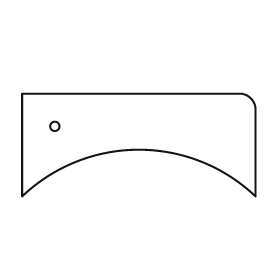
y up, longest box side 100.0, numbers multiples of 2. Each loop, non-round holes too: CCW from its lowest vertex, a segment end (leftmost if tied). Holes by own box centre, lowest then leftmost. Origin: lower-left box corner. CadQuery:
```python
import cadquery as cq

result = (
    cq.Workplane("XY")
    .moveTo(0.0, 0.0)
    .threePointArc((50.0, 20.0), (100.0, 0.0))
    .lineTo(100.0, 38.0)
    .threePointArc((98.0, 42.0), (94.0, 44.0))
    .lineTo(0.0, 44.0)
    .close()
    .moveTo(14.0, 30.0)
    .circle(2.0)
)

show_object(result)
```